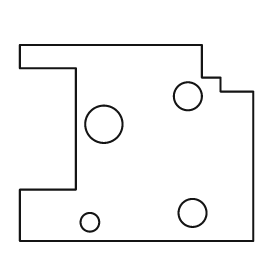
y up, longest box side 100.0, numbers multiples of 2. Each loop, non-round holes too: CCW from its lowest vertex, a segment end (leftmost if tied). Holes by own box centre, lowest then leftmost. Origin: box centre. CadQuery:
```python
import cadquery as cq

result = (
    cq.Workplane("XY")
    .moveTo(-50.0, -42.0)
    .lineTo(50.0, -42.0)
    .lineTo(50.0, 22.0)
    .lineTo(36.0, 22.0)
    .lineTo(36.0, 28.0)
    .lineTo(28.0, 28.0)
    .lineTo(28.0, 42.0)
    .lineTo(-50.0, 42.0)
    .lineTo(-50.0, 32.0)
    .lineTo(-26.0, 32.0)
    .lineTo(-26.0, -20.0)
    .lineTo(-50.0, -20.0)
    .close()
    .moveTo(-20.0, -34.0)
    .circle(4.0)
    .moveTo(24.0, -30.0)
    .circle(6.0)
    .moveTo(-14.0, 8.0)
    .circle(8.0)
    .moveTo(22.0, 20.0)
    .circle(6.0)
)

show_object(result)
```